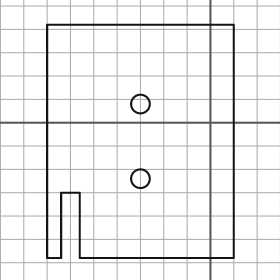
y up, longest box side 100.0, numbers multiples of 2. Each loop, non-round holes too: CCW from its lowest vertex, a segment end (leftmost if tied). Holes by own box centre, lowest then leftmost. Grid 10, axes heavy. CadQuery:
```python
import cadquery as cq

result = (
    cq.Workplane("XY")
    .moveTo(-70.0, -58.0)
    .lineTo(-64.0, -58.0)
    .lineTo(-64.0, -30.0)
    .lineTo(-56.0, -30.0)
    .lineTo(-56.0, -58.0)
    .lineTo(10.0, -58.0)
    .lineTo(10.0, 42.0)
    .lineTo(-70.0, 42.0)
    .close()
    .moveTo(-30.0, -24.0)
    .circle(4.0)
    .moveTo(-30.0, 8.0)
    .circle(4.0)
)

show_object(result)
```